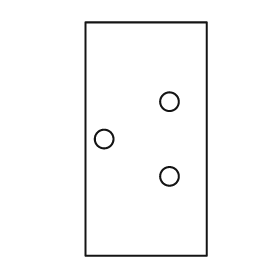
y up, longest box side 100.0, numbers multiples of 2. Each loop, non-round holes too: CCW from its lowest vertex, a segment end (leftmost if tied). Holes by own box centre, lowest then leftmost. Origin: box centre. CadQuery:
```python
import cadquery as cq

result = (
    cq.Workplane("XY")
    .moveTo(-26.0, -50.0)
    .lineTo(26.0, -50.0)
    .lineTo(26.0, 50.0)
    .lineTo(-26.0, 50.0)
    .close()
    .moveTo(10.0, -16.0)
    .circle(4.0)
    .moveTo(-18.0, 0.0)
    .circle(4.0)
    .moveTo(10.0, 16.0)
    .circle(4.0)
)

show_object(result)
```